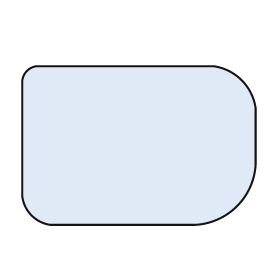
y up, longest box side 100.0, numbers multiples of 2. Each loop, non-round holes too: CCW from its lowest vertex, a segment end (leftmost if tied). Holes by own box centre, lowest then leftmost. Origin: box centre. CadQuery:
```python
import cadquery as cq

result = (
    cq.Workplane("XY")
    .moveTo(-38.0, -34.0)
    .lineTo(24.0, -34.0)
    .threePointArc((42.0, -26.0), (50.0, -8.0))
    .lineTo(50.0, 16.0)
    .threePointArc((44.0, 28.0), (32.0, 34.0))
    .lineTo(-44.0, 34.0)
    .threePointArc((-48.0, 32.0), (-50.0, 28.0))
    .lineTo(-50.0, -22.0)
    .threePointArc((-46.0, -30.0), (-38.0, -34.0))
    .close()
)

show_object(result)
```